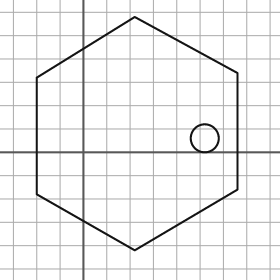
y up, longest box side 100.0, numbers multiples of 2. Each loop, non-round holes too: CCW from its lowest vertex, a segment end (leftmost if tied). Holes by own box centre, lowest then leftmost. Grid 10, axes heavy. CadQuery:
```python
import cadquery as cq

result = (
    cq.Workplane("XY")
    .moveTo(22.0, -42.0)
    .lineTo(66.0, -16.0)
    .lineTo(66.0, 34.0)
    .lineTo(22.0, 58.0)
    .lineTo(-20.0, 32.0)
    .lineTo(-20.0, -18.0)
    .close()
    .moveTo(52.0, 6.0)
    .circle(6.0)
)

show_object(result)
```